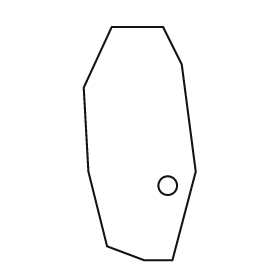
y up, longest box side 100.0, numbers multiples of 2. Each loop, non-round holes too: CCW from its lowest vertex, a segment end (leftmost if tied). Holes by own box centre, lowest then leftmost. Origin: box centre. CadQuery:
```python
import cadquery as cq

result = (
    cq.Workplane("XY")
    .moveTo(2.0, -50.0)
    .lineTo(14.0, -50.0)
    .lineTo(24.0, -12.0)
    .lineTo(18.0, 34.0)
    .lineTo(10.0, 50.0)
    .lineTo(-12.0, 50.0)
    .lineTo(-24.0, 24.0)
    .lineTo(-22.0, -12.0)
    .lineTo(-14.0, -44.0)
    .close()
    .moveTo(12.0, -18.0)
    .circle(4.0)
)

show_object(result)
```